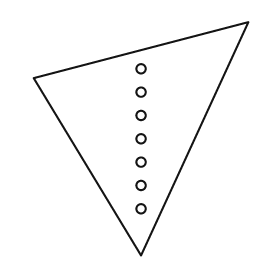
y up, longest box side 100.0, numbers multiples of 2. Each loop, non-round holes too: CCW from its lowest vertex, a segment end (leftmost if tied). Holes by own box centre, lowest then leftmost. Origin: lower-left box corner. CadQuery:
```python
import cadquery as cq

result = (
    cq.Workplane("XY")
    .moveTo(46.0, 0.0)
    .lineTo(92.0, 100.0)
    .lineTo(0.0, 76.0)
    .close()
    .moveTo(46.0, 20.0)
    .circle(2.0)
    .moveTo(46.0, 30.0)
    .circle(2.0)
    .moveTo(46.0, 40.0)
    .circle(2.0)
    .moveTo(46.0, 50.0)
    .circle(2.0)
    .moveTo(46.0, 60.0)
    .circle(2.0)
    .moveTo(46.0, 70.0)
    .circle(2.0)
    .moveTo(46.0, 80.0)
    .circle(2.0)
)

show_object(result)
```